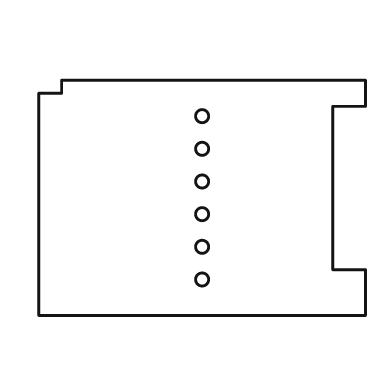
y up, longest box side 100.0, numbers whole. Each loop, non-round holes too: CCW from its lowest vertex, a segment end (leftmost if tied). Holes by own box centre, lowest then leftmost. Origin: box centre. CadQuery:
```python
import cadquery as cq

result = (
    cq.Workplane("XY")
    .moveTo(-50.0, -36.0)
    .lineTo(50.0, -36.0)
    .lineTo(50.0, -22.0)
    .lineTo(40.0, -22.0)
    .lineTo(40.0, 28.0)
    .lineTo(50.0, 28.0)
    .lineTo(50.0, 36.0)
    .lineTo(-43.0, 36.0)
    .lineTo(-43.0, 32.0)
    .lineTo(-50.0, 32.0)
    .close()
    .moveTo(0.0, -25.0)
    .circle(2.0)
    .moveTo(0.0, -15.0)
    .circle(2.0)
    .moveTo(0.0, -5.0)
    .circle(2.0)
    .moveTo(0.0, 5.0)
    .circle(2.0)
    .moveTo(0.0, 15.0)
    .circle(2.0)
    .moveTo(0.0, 25.0)
    .circle(2.0)
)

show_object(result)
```